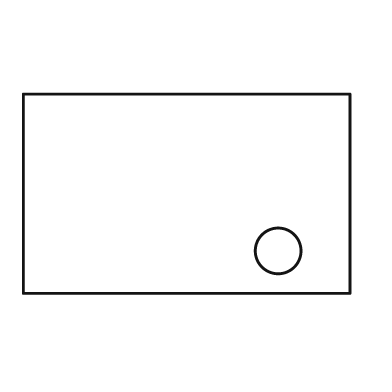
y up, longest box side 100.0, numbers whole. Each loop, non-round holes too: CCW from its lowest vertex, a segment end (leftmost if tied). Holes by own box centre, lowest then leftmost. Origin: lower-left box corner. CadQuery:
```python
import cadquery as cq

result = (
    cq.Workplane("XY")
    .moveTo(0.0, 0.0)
    .lineTo(100.0, 0.0)
    .lineTo(100.0, 61.0)
    .lineTo(0.0, 61.0)
    .close()
    .moveTo(78.0, 13.0)
    .circle(7.0)
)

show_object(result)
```